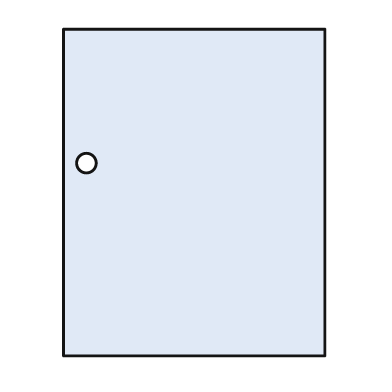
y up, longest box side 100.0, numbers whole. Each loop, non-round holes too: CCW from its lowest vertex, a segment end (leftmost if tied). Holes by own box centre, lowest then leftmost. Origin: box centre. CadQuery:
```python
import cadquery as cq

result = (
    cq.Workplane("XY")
    .moveTo(-40.0, -50.0)
    .lineTo(40.0, -50.0)
    .lineTo(40.0, 50.0)
    .lineTo(-40.0, 50.0)
    .close()
    .moveTo(-33.0, 9.0)
    .circle(3.0)
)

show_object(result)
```